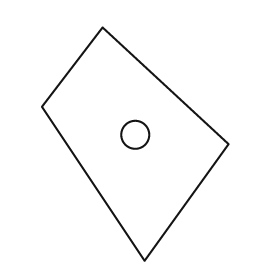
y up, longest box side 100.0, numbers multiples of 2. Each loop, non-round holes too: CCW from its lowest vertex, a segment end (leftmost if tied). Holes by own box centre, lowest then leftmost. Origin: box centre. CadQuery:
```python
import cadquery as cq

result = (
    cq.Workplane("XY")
    .moveTo(4.0, -50.0)
    .lineTo(40.0, 0.0)
    .lineTo(-14.0, 50.0)
    .lineTo(-40.0, 16.0)
    .close()
    .moveTo(0.0, 4.0)
    .circle(6.0)
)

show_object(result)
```